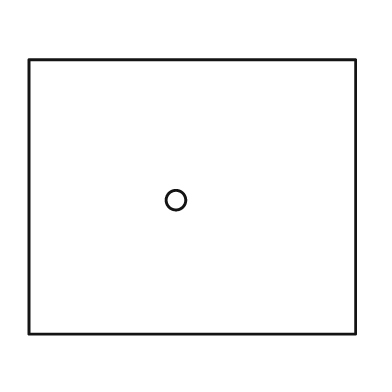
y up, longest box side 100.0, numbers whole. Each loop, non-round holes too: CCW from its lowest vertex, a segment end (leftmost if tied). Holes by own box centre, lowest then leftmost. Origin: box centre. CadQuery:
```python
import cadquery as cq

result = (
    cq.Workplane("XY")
    .moveTo(-50.0, -42.0)
    .lineTo(50.0, -42.0)
    .lineTo(50.0, 42.0)
    .lineTo(-50.0, 42.0)
    .close()
    .moveTo(-5.0, -1.0)
    .circle(3.0)
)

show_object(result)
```